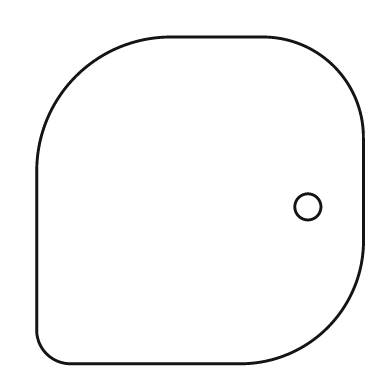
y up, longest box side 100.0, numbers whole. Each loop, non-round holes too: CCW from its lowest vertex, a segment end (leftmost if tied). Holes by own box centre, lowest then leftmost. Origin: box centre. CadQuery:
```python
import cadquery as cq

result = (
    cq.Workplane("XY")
    .moveTo(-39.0, -50.0)
    .lineTo(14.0, -50.0)
    .threePointArc((39.0, -39.0), (50.0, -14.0))
    .lineTo(50.0, 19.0)
    .threePointArc((41.0, 41.0), (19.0, 50.0))
    .lineTo(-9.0, 50.0)
    .threePointArc((-38.0, 38.0), (-50.0, 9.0))
    .lineTo(-50.0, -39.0)
    .threePointArc((-47.0, -47.0), (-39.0, -50.0))
    .close()
    .moveTo(33.0, -2.0)
    .circle(4.0)
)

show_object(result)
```